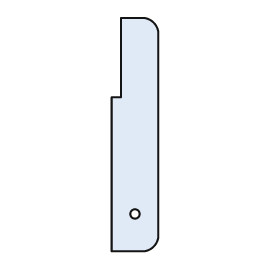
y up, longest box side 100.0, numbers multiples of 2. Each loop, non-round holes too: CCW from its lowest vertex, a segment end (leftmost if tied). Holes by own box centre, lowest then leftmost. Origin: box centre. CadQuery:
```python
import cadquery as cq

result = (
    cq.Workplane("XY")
    .moveTo(-10.0, -50.0)
    .lineTo(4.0, -50.0)
    .threePointArc((8.0, -48.0), (10.0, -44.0))
    .lineTo(10.0, 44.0)
    .threePointArc((8.0, 48.0), (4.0, 50.0))
    .lineTo(-6.0, 50.0)
    .lineTo(-6.0, 16.0)
    .lineTo(-10.0, 16.0)
    .close()
    .moveTo(0.0, -34.0)
    .circle(2.0)
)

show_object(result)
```